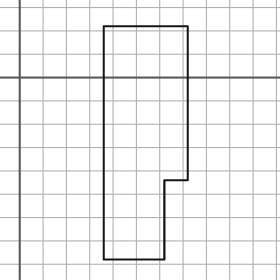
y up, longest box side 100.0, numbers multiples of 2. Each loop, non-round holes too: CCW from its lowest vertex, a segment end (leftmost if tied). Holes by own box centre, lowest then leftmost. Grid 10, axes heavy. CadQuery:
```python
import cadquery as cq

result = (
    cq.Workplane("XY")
    .moveTo(36.0, -78.0)
    .lineTo(62.0, -78.0)
    .lineTo(62.0, -44.0)
    .lineTo(72.0, -44.0)
    .lineTo(72.0, 22.0)
    .lineTo(36.0, 22.0)
    .close()
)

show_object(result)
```